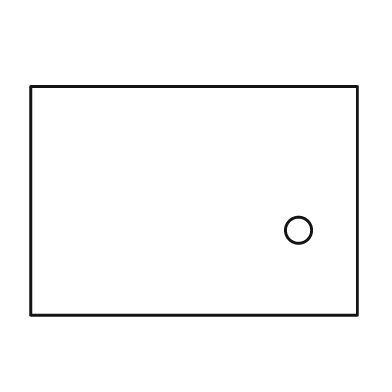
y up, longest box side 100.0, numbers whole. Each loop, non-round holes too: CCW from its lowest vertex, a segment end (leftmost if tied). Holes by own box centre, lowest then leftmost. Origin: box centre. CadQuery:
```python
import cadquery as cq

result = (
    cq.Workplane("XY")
    .moveTo(-50.0, -35.0)
    .lineTo(50.0, -35.0)
    .lineTo(50.0, 35.0)
    .lineTo(-50.0, 35.0)
    .close()
    .moveTo(32.0, -9.0)
    .circle(4.0)
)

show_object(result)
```